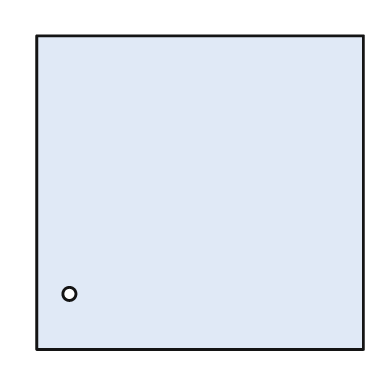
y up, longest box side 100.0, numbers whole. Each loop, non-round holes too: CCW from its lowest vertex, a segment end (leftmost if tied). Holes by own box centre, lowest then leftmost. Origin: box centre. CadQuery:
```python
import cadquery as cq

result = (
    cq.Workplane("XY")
    .moveTo(-50.0, -48.0)
    .lineTo(50.0, -48.0)
    .lineTo(50.0, 48.0)
    .lineTo(-50.0, 48.0)
    .close()
    .moveTo(-40.0, -31.0)
    .circle(2.0)
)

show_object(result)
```